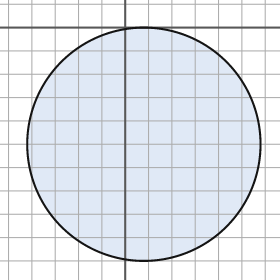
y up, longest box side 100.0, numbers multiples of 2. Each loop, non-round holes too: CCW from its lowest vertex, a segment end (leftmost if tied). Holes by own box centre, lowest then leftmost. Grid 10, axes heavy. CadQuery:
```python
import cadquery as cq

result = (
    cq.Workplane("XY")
    .moveTo(8.0, -50.0)
    .circle(50.0)
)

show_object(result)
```